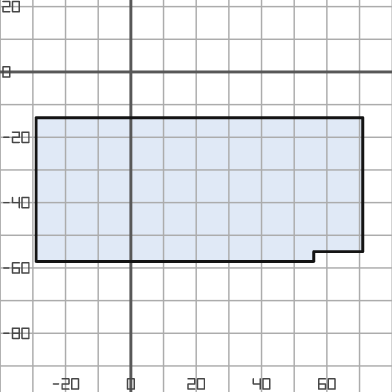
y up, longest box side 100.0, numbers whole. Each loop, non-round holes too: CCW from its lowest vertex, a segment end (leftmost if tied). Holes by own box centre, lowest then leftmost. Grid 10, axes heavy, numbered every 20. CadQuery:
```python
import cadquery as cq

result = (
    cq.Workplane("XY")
    .moveTo(-29.0, -58.0)
    .lineTo(56.0, -58.0)
    .lineTo(56.0, -55.0)
    .lineTo(71.0, -55.0)
    .lineTo(71.0, -14.0)
    .lineTo(-29.0, -14.0)
    .close()
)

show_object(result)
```